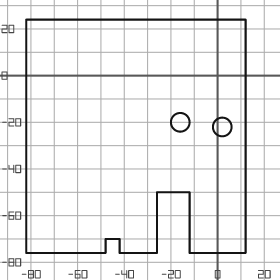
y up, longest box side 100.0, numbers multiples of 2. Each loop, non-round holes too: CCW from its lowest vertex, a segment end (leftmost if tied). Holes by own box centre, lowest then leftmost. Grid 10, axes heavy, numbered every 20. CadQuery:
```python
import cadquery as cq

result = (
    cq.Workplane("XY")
    .moveTo(-82.0, -76.0)
    .lineTo(-48.0, -76.0)
    .lineTo(-48.0, -70.0)
    .lineTo(-42.0, -70.0)
    .lineTo(-42.0, -76.0)
    .lineTo(-26.0, -76.0)
    .lineTo(-26.0, -50.0)
    .lineTo(-12.0, -50.0)
    .lineTo(-12.0, -76.0)
    .lineTo(12.0, -76.0)
    .lineTo(12.0, 24.0)
    .lineTo(-82.0, 24.0)
    .close()
    .moveTo(2.0, -22.0)
    .circle(4.0)
    .moveTo(-16.0, -20.0)
    .circle(4.0)
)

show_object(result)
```